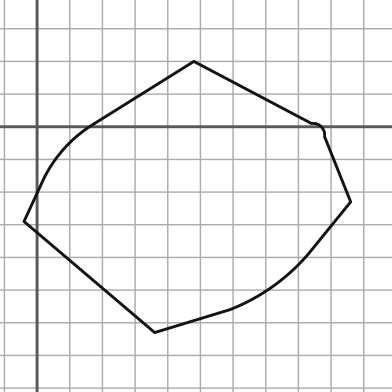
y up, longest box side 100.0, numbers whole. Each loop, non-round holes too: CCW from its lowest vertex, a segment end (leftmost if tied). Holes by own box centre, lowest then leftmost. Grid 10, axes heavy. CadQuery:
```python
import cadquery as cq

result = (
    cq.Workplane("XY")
    .moveTo(36.0, -63.0)
    .lineTo(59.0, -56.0)
    .threePointArc((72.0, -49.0), (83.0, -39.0))
    .lineTo(96.0, -23.0)
    .lineTo(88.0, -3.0)
    .threePointArc((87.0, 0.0), (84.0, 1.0))
    .lineTo(48.0, 20.0)
    .lineTo(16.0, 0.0)
    .threePointArc((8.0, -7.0), (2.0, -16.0))
    .lineTo(-4.0, -29.0)
    .close()
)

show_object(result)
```